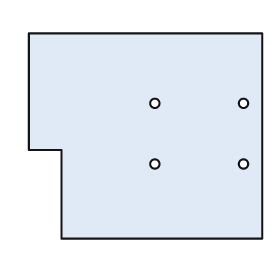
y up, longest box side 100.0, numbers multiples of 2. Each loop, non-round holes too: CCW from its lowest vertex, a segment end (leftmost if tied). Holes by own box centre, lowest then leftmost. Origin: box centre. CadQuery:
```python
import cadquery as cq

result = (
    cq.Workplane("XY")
    .moveTo(-36.0, -44.0)
    .lineTo(50.0, -44.0)
    .lineTo(50.0, 44.0)
    .lineTo(-50.0, 44.0)
    .lineTo(-50.0, -6.0)
    .lineTo(-36.0, -6.0)
    .close()
    .moveTo(4.0, -12.0)
    .circle(2.0)
    .moveTo(42.0, -12.0)
    .circle(2.0)
    .moveTo(4.0, 14.0)
    .circle(2.0)
    .moveTo(42.0, 14.0)
    .circle(2.0)
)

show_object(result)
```